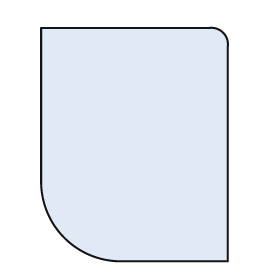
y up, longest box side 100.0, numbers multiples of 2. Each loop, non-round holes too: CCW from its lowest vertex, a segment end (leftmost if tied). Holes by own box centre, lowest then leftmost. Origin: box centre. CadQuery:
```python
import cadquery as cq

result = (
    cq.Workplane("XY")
    .moveTo(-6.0, -50.0)
    .lineTo(40.0, -50.0)
    .lineTo(40.0, 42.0)
    .threePointArc((38.0, 48.0), (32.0, 50.0))
    .lineTo(-40.0, 50.0)
    .lineTo(-40.0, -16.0)
    .threePointArc((-30.0, -40.0), (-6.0, -50.0))
    .close()
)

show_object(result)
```